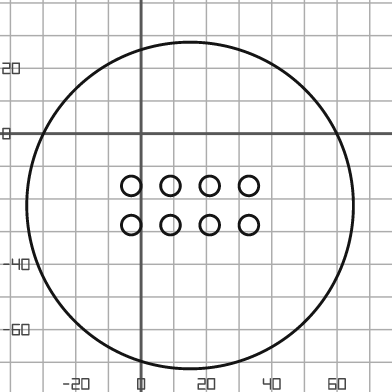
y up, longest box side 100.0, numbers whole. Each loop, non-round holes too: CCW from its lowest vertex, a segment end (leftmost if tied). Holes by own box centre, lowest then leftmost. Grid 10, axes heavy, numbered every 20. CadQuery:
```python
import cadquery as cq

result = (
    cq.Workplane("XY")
    .moveTo(15.0, -22.0)
    .circle(50.0)
    .moveTo(-3.0, -28.0)
    .circle(3.0)
    .moveTo(9.0, -28.0)
    .circle(3.0)
    .moveTo(21.0, -28.0)
    .circle(3.0)
    .moveTo(33.0, -28.0)
    .circle(3.0)
    .moveTo(-3.0, -16.0)
    .circle(3.0)
    .moveTo(9.0, -16.0)
    .circle(3.0)
    .moveTo(21.0, -16.0)
    .circle(3.0)
    .moveTo(33.0, -16.0)
    .circle(3.0)
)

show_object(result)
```